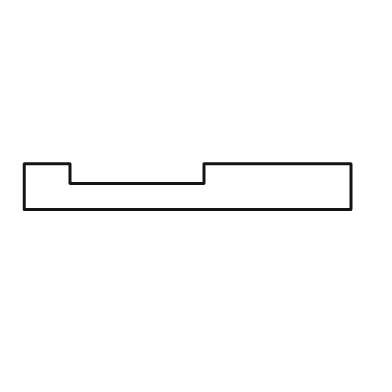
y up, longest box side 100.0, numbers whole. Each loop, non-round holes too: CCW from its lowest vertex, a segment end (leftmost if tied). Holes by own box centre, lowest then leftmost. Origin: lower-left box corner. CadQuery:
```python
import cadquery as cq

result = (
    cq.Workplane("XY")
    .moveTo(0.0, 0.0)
    .lineTo(100.0, 0.0)
    .lineTo(100.0, 14.0)
    .lineTo(55.0, 14.0)
    .lineTo(55.0, 8.0)
    .lineTo(14.0, 8.0)
    .lineTo(14.0, 14.0)
    .lineTo(0.0, 14.0)
    .close()
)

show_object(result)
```